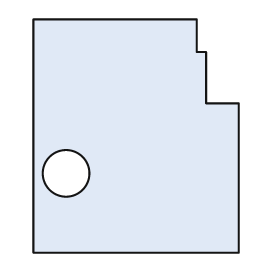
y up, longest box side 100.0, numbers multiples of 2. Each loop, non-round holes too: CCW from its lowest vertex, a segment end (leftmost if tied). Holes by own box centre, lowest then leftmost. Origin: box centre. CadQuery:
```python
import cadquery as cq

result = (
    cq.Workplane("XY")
    .moveTo(-44.0, -50.0)
    .lineTo(44.0, -50.0)
    .lineTo(44.0, 14.0)
    .lineTo(30.0, 14.0)
    .lineTo(30.0, 36.0)
    .lineTo(26.0, 36.0)
    .lineTo(26.0, 50.0)
    .lineTo(-44.0, 50.0)
    .close()
    .moveTo(-30.0, -16.0)
    .circle(10.0)
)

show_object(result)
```